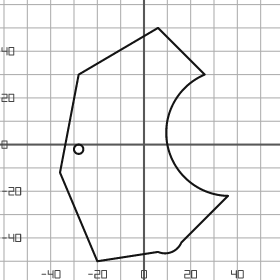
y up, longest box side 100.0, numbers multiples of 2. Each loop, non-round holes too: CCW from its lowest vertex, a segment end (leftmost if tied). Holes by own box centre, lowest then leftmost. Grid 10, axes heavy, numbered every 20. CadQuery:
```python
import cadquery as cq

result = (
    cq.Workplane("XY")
    .moveTo(-20.0, -50.0)
    .lineTo(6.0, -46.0)
    .threePointArc((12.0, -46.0), (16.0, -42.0))
    .lineTo(36.0, -22.0)
    .threePointArc((10.0, 0.0), (26.0, 30.0))
    .lineTo(6.0, 50.0)
    .lineTo(-28.0, 30.0)
    .lineTo(-36.0, -12.0)
    .close()
    .moveTo(-28.0, -2.0)
    .circle(2.0)
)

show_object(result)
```